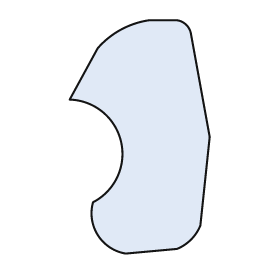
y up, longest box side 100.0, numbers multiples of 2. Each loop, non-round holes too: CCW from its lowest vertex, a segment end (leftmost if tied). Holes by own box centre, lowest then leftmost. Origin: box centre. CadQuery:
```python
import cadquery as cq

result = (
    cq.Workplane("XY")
    .moveTo(-6.0, -50.0)
    .lineTo(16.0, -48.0)
    .threePointArc((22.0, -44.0), (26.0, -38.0))
    .lineTo(30.0, 0.0)
    .lineTo(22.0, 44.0)
    .threePointArc((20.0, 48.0), (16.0, 50.0))
    .lineTo(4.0, 50.0)
    .threePointArc((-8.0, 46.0), (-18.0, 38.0))
    .lineTo(-30.0, 16.0)
    .threePointArc((-8.0, -2.0), (-20.0, -28.0))
    .threePointArc((-18.0, -42.0), (-6.0, -50.0))
    .close()
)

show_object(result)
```